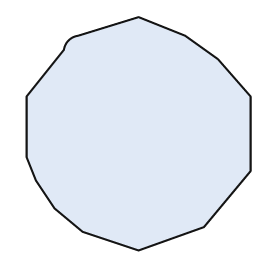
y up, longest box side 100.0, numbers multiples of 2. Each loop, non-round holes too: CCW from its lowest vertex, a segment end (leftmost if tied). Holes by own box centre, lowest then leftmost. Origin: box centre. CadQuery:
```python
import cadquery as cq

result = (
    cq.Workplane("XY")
    .moveTo(0.0, -50.0)
    .lineTo(28.0, -40.0)
    .lineTo(48.0, -16.0)
    .lineTo(48.0, 16.0)
    .lineTo(34.0, 32.0)
    .lineTo(20.0, 42.0)
    .lineTo(0.0, 50.0)
    .lineTo(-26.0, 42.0)
    .threePointArc((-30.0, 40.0), (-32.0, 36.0))
    .lineTo(-48.0, 16.0)
    .lineTo(-48.0, -10.0)
    .lineTo(-44.0, -20.0)
    .lineTo(-36.0, -32.0)
    .lineTo(-24.0, -42.0)
    .close()
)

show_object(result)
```